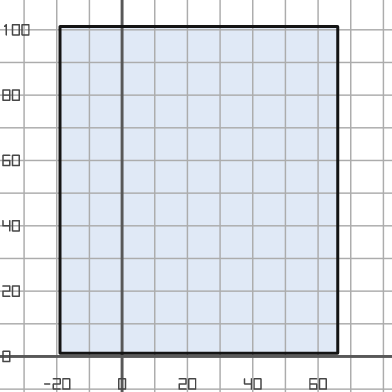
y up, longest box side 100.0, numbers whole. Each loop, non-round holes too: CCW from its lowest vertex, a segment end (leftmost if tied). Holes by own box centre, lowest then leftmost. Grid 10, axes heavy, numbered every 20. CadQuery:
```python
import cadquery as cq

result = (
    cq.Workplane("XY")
    .moveTo(-19.0, 1.0)
    .lineTo(66.0, 1.0)
    .lineTo(66.0, 101.0)
    .lineTo(-19.0, 101.0)
    .close()
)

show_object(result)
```